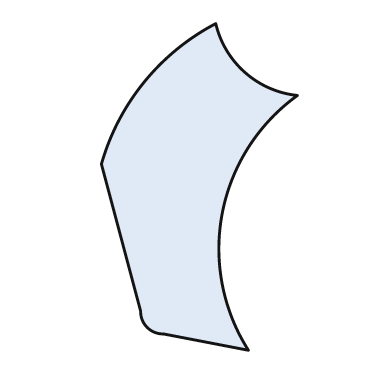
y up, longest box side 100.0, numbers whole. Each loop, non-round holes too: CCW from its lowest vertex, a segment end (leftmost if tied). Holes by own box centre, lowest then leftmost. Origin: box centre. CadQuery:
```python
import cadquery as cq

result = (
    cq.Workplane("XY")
    .moveTo(15.0, -50.0)
    .threePointArc((7.0, -8.0), (30.0, 28.0))
    .threePointArc((14.0, 35.0), (5.0, 50.0))
    .threePointArc((-17.0, 32.0), (-30.0, 7.0))
    .lineTo(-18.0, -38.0)
    .threePointArc((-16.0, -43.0), (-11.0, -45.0))
    .close()
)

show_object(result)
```